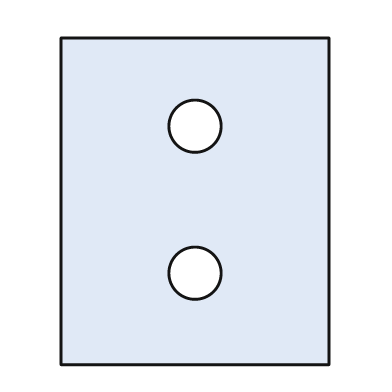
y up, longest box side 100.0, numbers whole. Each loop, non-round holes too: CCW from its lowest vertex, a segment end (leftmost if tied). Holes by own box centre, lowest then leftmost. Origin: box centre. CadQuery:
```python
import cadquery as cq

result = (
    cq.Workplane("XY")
    .moveTo(-41.0, -50.0)
    .lineTo(41.0, -50.0)
    .lineTo(41.0, 50.0)
    .lineTo(-41.0, 50.0)
    .close()
    .moveTo(0.0, -22.0)
    .circle(8.0)
    .moveTo(0.0, 23.0)
    .circle(8.0)
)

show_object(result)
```